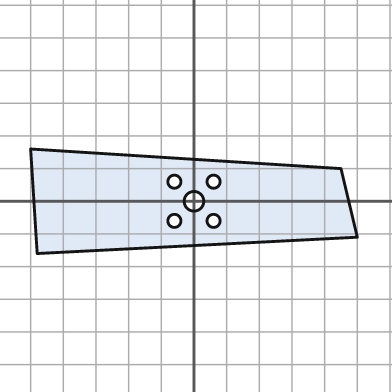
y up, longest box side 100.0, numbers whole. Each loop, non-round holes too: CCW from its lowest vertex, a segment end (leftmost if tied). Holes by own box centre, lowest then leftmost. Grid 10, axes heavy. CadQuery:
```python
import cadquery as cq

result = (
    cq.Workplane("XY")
    .moveTo(-48.0, -16.0)
    .lineTo(50.0, -11.0)
    .lineTo(45.0, 10.0)
    .lineTo(-50.0, 16.0)
    .close()
    .moveTo(-6.0, -6.0)
    .circle(2.0)
    .moveTo(6.0, -6.0)
    .circle(2.0)
    .moveTo(0.0, 0.0)
    .circle(3.0)
    .moveTo(-6.0, 6.0)
    .circle(2.0)
    .moveTo(6.0, 6.0)
    .circle(2.0)
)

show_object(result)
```